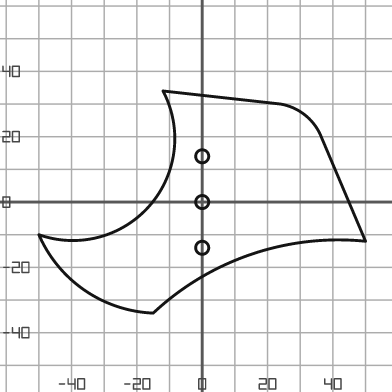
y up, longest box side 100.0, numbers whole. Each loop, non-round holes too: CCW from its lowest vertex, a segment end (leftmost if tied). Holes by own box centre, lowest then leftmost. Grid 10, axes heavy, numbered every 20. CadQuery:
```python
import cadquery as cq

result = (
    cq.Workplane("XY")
    .moveTo(-15.0, -34.0)
    .threePointArc((15.0, -16.0), (50.0, -12.0))
    .lineTo(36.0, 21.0)
    .threePointArc((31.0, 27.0), (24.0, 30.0))
    .lineTo(-12.0, 34.0)
    .threePointArc((-16.0, -1.0), (-50.0, -10.0))
    .threePointArc((-36.0, -27.0), (-15.0, -34.0))
    .close()
    .moveTo(0.0, -14.0)
    .circle(2.0)
    .moveTo(0.0, 0.0)
    .circle(2.0)
    .moveTo(0.0, 14.0)
    .circle(2.0)
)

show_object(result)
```